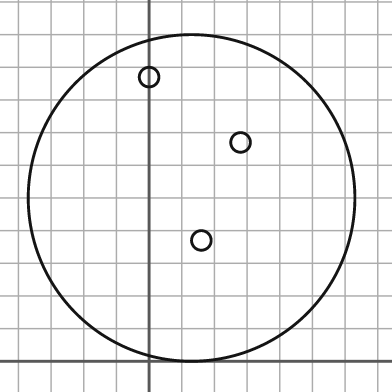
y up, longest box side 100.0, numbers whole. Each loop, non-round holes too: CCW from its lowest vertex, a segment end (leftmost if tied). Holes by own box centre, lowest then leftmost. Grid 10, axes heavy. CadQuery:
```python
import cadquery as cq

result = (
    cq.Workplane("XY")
    .moveTo(13.0, 50.0)
    .circle(50.0)
    .moveTo(16.0, 37.0)
    .circle(3.0)
    .moveTo(28.0, 67.0)
    .circle(3.0)
    .moveTo(0.0, 87.0)
    .circle(3.0)
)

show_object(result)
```